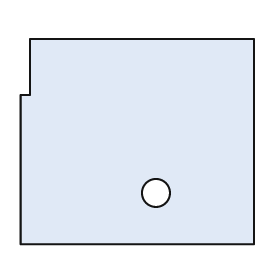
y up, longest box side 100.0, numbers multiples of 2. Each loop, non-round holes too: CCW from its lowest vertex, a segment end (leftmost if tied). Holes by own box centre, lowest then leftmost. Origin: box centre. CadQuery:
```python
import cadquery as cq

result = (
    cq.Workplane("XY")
    .moveTo(-50.0, -44.0)
    .lineTo(50.0, -44.0)
    .lineTo(50.0, 44.0)
    .lineTo(-46.0, 44.0)
    .lineTo(-46.0, 20.0)
    .lineTo(-50.0, 20.0)
    .close()
    .moveTo(8.0, -22.0)
    .circle(6.0)
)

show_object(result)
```